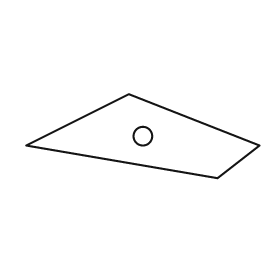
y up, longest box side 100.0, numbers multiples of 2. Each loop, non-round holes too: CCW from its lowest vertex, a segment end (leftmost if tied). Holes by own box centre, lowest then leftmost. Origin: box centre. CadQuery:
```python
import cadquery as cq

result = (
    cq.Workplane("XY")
    .moveTo(32.0, -18.0)
    .lineTo(50.0, -4.0)
    .lineTo(-6.0, 18.0)
    .lineTo(-50.0, -4.0)
    .close()
    .moveTo(0.0, 0.0)
    .circle(4.0)
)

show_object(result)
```